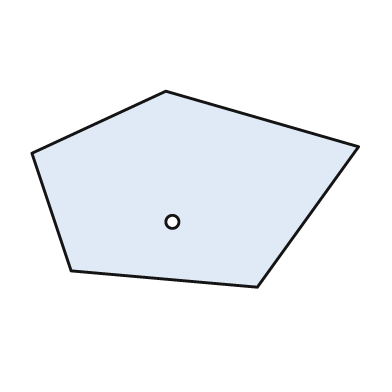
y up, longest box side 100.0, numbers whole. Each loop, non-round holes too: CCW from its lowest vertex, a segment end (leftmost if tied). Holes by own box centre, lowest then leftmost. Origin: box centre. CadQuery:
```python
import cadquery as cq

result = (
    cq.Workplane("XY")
    .moveTo(19.0, -30.0)
    .lineTo(50.0, 13.0)
    .lineTo(-9.0, 30.0)
    .lineTo(-50.0, 11.0)
    .lineTo(-38.0, -25.0)
    .close()
    .moveTo(-7.0, -10.0)
    .circle(2.0)
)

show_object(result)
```